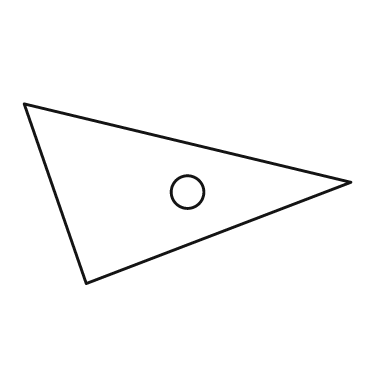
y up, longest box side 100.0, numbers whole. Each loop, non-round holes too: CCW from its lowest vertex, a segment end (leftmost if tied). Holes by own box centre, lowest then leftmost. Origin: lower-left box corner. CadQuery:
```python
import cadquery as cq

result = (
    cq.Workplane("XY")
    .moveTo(19.0, 0.0)
    .lineTo(100.0, 31.0)
    .lineTo(0.0, 55.0)
    .close()
    .moveTo(50.0, 28.0)
    .circle(5.0)
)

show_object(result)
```